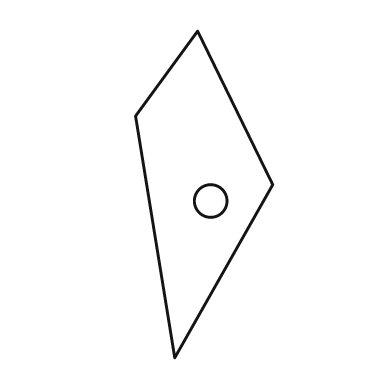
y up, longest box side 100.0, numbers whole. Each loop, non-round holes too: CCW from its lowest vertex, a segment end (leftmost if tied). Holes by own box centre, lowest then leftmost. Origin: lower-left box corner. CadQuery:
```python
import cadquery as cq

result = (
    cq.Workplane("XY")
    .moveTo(12.0, 0.0)
    .lineTo(42.0, 53.0)
    .lineTo(19.0, 100.0)
    .lineTo(0.0, 74.0)
    .close()
    .moveTo(23.0, 48.0)
    .circle(5.0)
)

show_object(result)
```